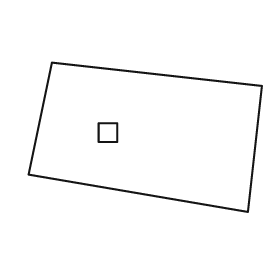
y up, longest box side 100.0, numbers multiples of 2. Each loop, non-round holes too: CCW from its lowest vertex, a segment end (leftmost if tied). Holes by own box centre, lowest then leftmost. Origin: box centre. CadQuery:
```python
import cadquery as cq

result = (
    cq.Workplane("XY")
    .moveTo(44.0, -32.0)
    .lineTo(50.0, 22.0)
    .lineTo(-40.0, 32.0)
    .lineTo(-50.0, -16.0)
    .close()
    .moveTo(-20.0, -2.0)
    .lineTo(-12.0, -2.0)
    .lineTo(-12.0, 6.0)
    .lineTo(-20.0, 6.0)
    .close()
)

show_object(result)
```